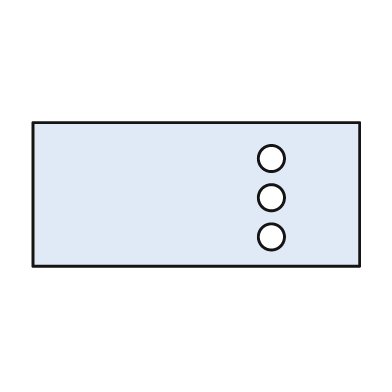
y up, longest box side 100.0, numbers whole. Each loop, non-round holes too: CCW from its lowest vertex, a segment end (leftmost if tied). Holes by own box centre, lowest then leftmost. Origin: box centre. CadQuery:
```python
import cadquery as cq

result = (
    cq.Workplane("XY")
    .moveTo(-50.0, -22.0)
    .lineTo(50.0, -22.0)
    .lineTo(50.0, 22.0)
    .lineTo(-50.0, 22.0)
    .close()
    .moveTo(23.0, -13.0)
    .circle(4.0)
    .moveTo(23.0, -1.0)
    .circle(4.0)
    .moveTo(23.0, 11.0)
    .circle(4.0)
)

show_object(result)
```